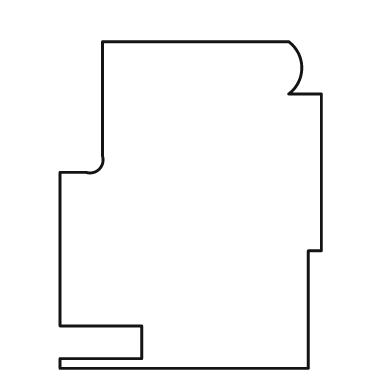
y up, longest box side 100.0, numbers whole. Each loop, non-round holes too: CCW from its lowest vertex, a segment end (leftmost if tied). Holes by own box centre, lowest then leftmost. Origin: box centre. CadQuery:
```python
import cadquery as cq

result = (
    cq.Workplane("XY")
    .moveTo(-40.0, -50.0)
    .lineTo(36.0, -50.0)
    .lineTo(36.0, -14.0)
    .lineTo(40.0, -14.0)
    .lineTo(40.0, 34.0)
    .lineTo(30.0, 34.0)
    .threePointArc((34.0, 42.0), (30.0, 50.0))
    .lineTo(-27.0, 50.0)
    .lineTo(-27.0, 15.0)
    .threePointArc((-28.0, 11.0), (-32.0, 10.0))
    .lineTo(-40.0, 10.0)
    .lineTo(-40.0, -37.0)
    .lineTo(-15.0, -37.0)
    .lineTo(-15.0, -47.0)
    .lineTo(-40.0, -47.0)
    .close()
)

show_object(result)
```